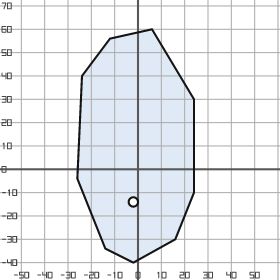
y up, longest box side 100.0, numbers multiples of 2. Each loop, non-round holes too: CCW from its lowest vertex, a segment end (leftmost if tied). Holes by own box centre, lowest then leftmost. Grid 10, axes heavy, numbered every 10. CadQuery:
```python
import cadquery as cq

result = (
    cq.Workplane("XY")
    .moveTo(-2.0, -40.0)
    .lineTo(16.0, -30.0)
    .lineTo(24.0, -10.0)
    .lineTo(24.0, 30.0)
    .lineTo(6.0, 60.0)
    .lineTo(-12.0, 56.0)
    .lineTo(-24.0, 40.0)
    .lineTo(-26.0, -4.0)
    .lineTo(-14.0, -34.0)
    .close()
    .moveTo(-2.0, -14.0)
    .circle(2.0)
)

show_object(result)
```